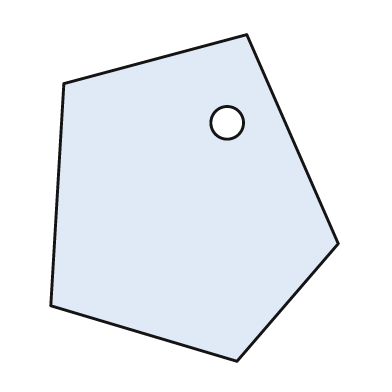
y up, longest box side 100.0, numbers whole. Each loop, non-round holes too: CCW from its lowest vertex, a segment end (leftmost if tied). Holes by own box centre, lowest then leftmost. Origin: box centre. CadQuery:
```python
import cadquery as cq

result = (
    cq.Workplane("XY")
    .moveTo(13.0, -50.0)
    .lineTo(44.0, -14.0)
    .lineTo(16.0, 50.0)
    .lineTo(-40.0, 35.0)
    .lineTo(-44.0, -33.0)
    .close()
    .moveTo(10.0, 23.0)
    .circle(5.0)
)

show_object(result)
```